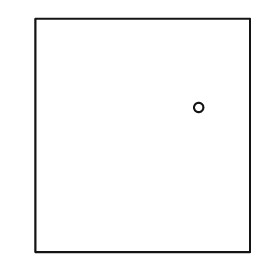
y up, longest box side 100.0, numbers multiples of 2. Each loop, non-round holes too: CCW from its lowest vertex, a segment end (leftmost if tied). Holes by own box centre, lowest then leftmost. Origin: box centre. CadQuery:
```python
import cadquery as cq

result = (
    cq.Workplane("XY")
    .moveTo(-46.0, -50.0)
    .lineTo(46.0, -50.0)
    .lineTo(46.0, 50.0)
    .lineTo(-46.0, 50.0)
    .close()
    .moveTo(24.0, 12.0)
    .circle(2.0)
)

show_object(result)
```